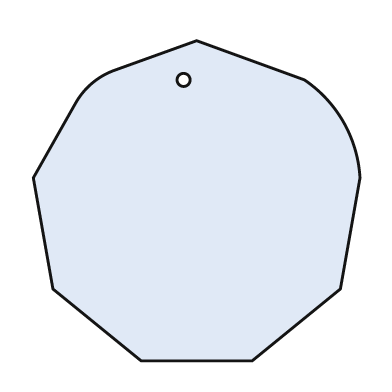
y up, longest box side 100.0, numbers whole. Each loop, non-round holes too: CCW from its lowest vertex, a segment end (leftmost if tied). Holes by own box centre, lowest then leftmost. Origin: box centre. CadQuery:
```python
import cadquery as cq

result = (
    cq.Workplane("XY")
    .moveTo(-17.0, -49.0)
    .lineTo(17.0, -49.0)
    .lineTo(44.0, -27.0)
    .lineTo(50.0, 7.0)
    .threePointArc((45.0, 24.0), (33.0, 37.0))
    .lineTo(0.0, 49.0)
    .lineTo(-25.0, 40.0)
    .threePointArc((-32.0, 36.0), (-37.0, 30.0))
    .lineTo(-50.0, 7.0)
    .lineTo(-44.0, -27.0)
    .close()
    .moveTo(-4.0, 37.0)
    .circle(2.0)
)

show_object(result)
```